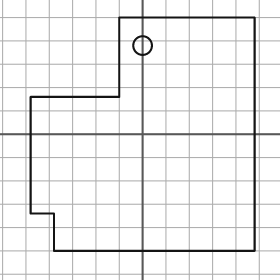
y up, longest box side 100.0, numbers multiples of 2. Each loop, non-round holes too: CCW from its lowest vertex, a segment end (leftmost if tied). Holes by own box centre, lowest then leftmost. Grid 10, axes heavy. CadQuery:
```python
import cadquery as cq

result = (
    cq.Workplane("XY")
    .moveTo(-38.0, -50.0)
    .lineTo(48.0, -50.0)
    .lineTo(48.0, 50.0)
    .lineTo(-10.0, 50.0)
    .lineTo(-10.0, 16.0)
    .lineTo(-48.0, 16.0)
    .lineTo(-48.0, -34.0)
    .lineTo(-38.0, -34.0)
    .close()
    .moveTo(0.0, 38.0)
    .circle(4.0)
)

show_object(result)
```